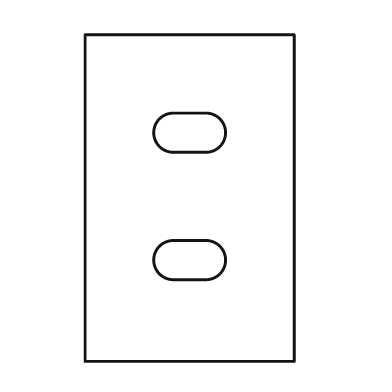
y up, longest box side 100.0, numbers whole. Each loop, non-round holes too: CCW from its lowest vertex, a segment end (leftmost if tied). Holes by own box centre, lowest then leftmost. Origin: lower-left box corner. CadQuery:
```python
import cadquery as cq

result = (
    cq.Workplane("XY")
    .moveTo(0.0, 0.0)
    .lineTo(64.0, 0.0)
    .lineTo(64.0, 100.0)
    .lineTo(0.0, 100.0)
    .close()
    .moveTo(27.0, 25.0)
    .lineTo(37.0, 25.0)
    .threePointArc((43.0, 31.0), (37.0, 37.0))
    .lineTo(27.0, 37.0)
    .threePointArc((21.0, 31.0), (27.0, 25.0))
    .close()
    .moveTo(27.0, 64.0)
    .lineTo(37.0, 64.0)
    .threePointArc((43.0, 70.0), (37.0, 76.0))
    .lineTo(27.0, 76.0)
    .threePointArc((21.0, 70.0), (27.0, 64.0))
    .close()
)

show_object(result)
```